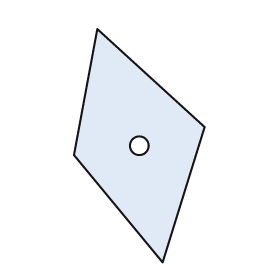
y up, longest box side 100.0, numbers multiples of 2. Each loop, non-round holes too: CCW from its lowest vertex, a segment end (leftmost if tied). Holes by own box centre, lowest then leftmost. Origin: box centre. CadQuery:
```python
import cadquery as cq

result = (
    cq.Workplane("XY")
    .moveTo(10.0, -50.0)
    .lineTo(28.0, 8.0)
    .lineTo(-18.0, 50.0)
    .lineTo(-28.0, -4.0)
    .close()
    .moveTo(0.0, 0.0)
    .circle(4.0)
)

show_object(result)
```